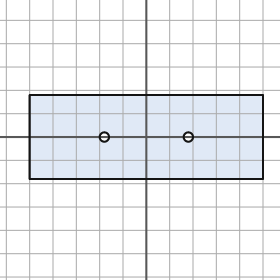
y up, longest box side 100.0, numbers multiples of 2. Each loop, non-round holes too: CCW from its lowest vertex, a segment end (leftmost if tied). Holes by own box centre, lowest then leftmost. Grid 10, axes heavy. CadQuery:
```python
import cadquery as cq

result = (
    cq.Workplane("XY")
    .moveTo(-50.0, -18.0)
    .lineTo(50.0, -18.0)
    .lineTo(50.0, 18.0)
    .lineTo(-50.0, 18.0)
    .close()
    .moveTo(-18.0, 0.0)
    .circle(2.0)
    .moveTo(18.0, 0.0)
    .circle(2.0)
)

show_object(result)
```